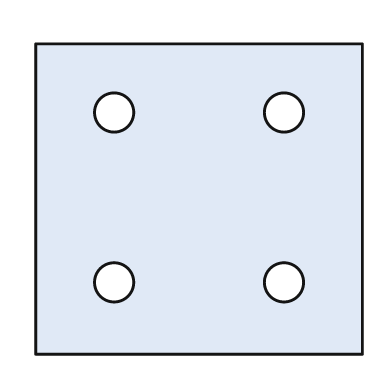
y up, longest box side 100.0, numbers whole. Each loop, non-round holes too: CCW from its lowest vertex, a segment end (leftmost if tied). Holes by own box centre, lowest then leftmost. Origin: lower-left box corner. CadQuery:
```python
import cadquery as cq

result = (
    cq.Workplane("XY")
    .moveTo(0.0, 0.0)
    .lineTo(100.0, 0.0)
    .lineTo(100.0, 95.0)
    .lineTo(0.0, 95.0)
    .close()
    .moveTo(24.0, 22.0)
    .circle(6.0)
    .moveTo(76.0, 22.0)
    .circle(6.0)
    .moveTo(24.0, 74.0)
    .circle(6.0)
    .moveTo(76.0, 74.0)
    .circle(6.0)
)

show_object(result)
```